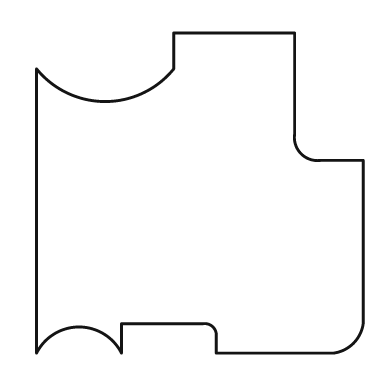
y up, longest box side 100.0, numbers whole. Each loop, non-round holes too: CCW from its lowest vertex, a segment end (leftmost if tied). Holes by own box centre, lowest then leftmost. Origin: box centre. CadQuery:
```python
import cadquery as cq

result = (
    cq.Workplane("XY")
    .moveTo(-50.0, -49.0)
    .threePointArc((-37.0, -41.0), (-24.0, -49.0))
    .lineTo(-24.0, -40.0)
    .lineTo(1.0, -40.0)
    .threePointArc((4.0, -41.0), (5.0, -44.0))
    .lineTo(5.0, -49.0)
    .lineTo(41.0, -49.0)
    .threePointArc((47.0, -46.0), (50.0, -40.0))
    .lineTo(50.0, 10.0)
    .lineTo(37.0, 10.0)
    .threePointArc((31.0, 12.0), (29.0, 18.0))
    .lineTo(29.0, 49.0)
    .lineTo(-8.0, 49.0)
    .lineTo(-8.0, 38.0)
    .threePointArc((-29.0, 28.0), (-50.0, 38.0))
    .close()
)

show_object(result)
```